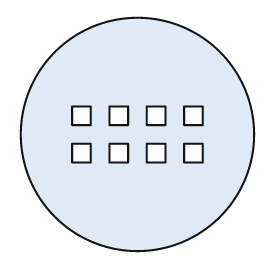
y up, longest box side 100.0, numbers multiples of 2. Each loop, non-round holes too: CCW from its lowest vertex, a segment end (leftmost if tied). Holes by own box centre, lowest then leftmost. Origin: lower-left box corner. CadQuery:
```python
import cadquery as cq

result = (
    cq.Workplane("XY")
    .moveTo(50.0, 50.0)
    .circle(50.0)
    .moveTo(22.0, 38.0)
    .lineTo(30.0, 38.0)
    .lineTo(30.0, 46.0)
    .lineTo(22.0, 46.0)
    .close()
    .moveTo(38.0, 38.0)
    .lineTo(46.0, 38.0)
    .lineTo(46.0, 46.0)
    .lineTo(38.0, 46.0)
    .close()
    .moveTo(54.0, 38.0)
    .lineTo(62.0, 38.0)
    .lineTo(62.0, 46.0)
    .lineTo(54.0, 46.0)
    .close()
    .moveTo(70.0, 38.0)
    .lineTo(78.0, 38.0)
    .lineTo(78.0, 46.0)
    .lineTo(70.0, 46.0)
    .close()
    .moveTo(22.0, 54.0)
    .lineTo(30.0, 54.0)
    .lineTo(30.0, 62.0)
    .lineTo(22.0, 62.0)
    .close()
    .moveTo(38.0, 54.0)
    .lineTo(46.0, 54.0)
    .lineTo(46.0, 62.0)
    .lineTo(38.0, 62.0)
    .close()
    .moveTo(54.0, 54.0)
    .lineTo(62.0, 54.0)
    .lineTo(62.0, 62.0)
    .lineTo(54.0, 62.0)
    .close()
    .moveTo(70.0, 54.0)
    .lineTo(78.0, 54.0)
    .lineTo(78.0, 62.0)
    .lineTo(70.0, 62.0)
    .close()
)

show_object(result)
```